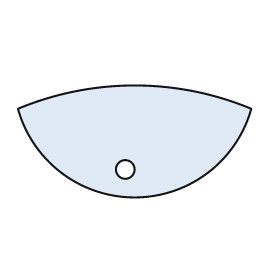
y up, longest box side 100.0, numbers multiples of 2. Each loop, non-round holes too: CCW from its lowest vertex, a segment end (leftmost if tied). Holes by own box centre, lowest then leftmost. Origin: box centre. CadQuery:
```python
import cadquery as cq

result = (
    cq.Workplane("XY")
    .moveTo(-50.0, 14.0)
    .threePointArc((0.0, -24.0), (50.0, 14.0))
    .threePointArc((0.0, 24.0), (-50.0, 14.0))
    .close()
    .moveTo(-4.0, -12.0)
    .circle(4.0)
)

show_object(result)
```